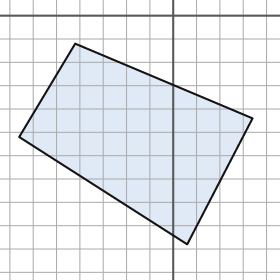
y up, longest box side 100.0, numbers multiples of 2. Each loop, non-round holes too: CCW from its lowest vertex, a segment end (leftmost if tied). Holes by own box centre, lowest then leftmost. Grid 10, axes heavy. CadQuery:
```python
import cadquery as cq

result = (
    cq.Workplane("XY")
    .moveTo(6.0, -98.0)
    .lineTo(34.0, -44.0)
    .lineTo(-42.0, -12.0)
    .lineTo(-66.0, -52.0)
    .close()
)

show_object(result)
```